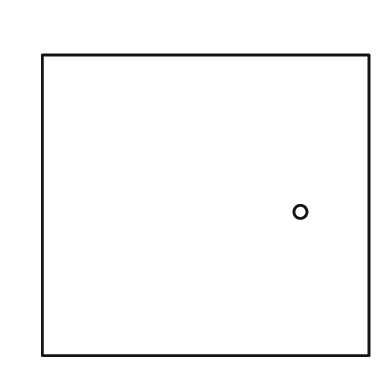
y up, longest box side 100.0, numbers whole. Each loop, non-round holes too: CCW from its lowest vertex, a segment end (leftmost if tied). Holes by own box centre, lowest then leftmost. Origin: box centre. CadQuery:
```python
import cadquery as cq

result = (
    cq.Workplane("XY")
    .moveTo(-50.0, -46.0)
    .lineTo(50.0, -46.0)
    .lineTo(50.0, 46.0)
    .lineTo(-50.0, 46.0)
    .close()
    .moveTo(29.0, -2.0)
    .circle(2.0)
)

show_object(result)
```